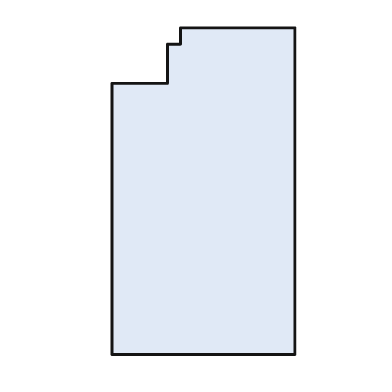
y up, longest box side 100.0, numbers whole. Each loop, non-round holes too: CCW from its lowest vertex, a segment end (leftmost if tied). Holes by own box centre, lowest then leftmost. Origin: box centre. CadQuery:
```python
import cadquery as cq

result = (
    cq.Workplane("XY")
    .moveTo(-28.0, -50.0)
    .lineTo(28.0, -50.0)
    .lineTo(28.0, 50.0)
    .lineTo(-7.0, 50.0)
    .lineTo(-7.0, 45.0)
    .lineTo(-11.0, 45.0)
    .lineTo(-11.0, 33.0)
    .lineTo(-28.0, 33.0)
    .close()
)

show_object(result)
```